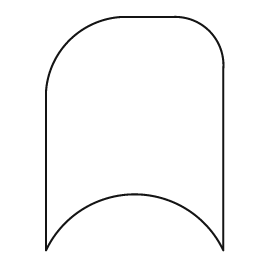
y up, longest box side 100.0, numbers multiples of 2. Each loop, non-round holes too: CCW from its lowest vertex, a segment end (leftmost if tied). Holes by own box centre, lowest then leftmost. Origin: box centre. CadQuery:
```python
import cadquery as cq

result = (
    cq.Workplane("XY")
    .moveTo(-38.0, -50.0)
    .threePointArc((0.0, -26.0), (38.0, -50.0))
    .lineTo(38.0, 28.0)
    .threePointArc((32.0, 44.0), (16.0, 50.0))
    .lineTo(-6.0, 50.0)
    .threePointArc((-28.0, 40.0), (-38.0, 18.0))
    .close()
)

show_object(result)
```